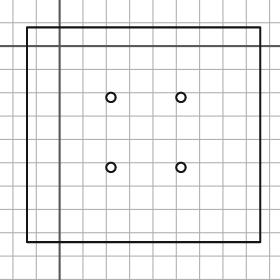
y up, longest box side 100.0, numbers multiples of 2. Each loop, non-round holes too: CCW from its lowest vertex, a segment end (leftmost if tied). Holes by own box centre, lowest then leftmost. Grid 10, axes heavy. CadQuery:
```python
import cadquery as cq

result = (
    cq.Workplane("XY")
    .moveTo(-14.0, -84.0)
    .lineTo(86.0, -84.0)
    .lineTo(86.0, 8.0)
    .lineTo(-14.0, 8.0)
    .close()
    .moveTo(22.0, -52.0)
    .circle(2.0)
    .moveTo(52.0, -52.0)
    .circle(2.0)
    .moveTo(22.0, -22.0)
    .circle(2.0)
    .moveTo(52.0, -22.0)
    .circle(2.0)
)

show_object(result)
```